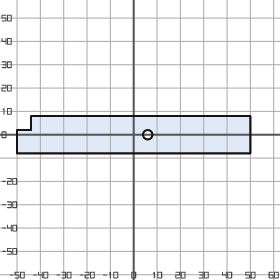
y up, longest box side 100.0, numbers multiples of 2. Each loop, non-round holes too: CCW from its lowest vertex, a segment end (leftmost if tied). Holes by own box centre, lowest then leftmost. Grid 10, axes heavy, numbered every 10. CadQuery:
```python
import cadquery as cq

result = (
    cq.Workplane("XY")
    .moveTo(-50.0, -8.0)
    .lineTo(50.0, -8.0)
    .lineTo(50.0, 8.0)
    .lineTo(-44.0, 8.0)
    .lineTo(-44.0, 2.0)
    .lineTo(-50.0, 2.0)
    .close()
    .moveTo(6.0, 0.0)
    .circle(2.0)
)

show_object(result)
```